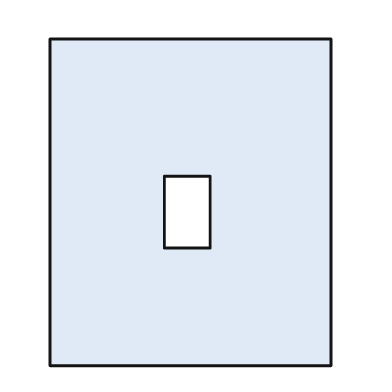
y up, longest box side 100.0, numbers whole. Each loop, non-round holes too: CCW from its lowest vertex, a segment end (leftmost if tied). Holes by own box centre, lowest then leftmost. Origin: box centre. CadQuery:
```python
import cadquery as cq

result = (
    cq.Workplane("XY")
    .moveTo(-43.0, -50.0)
    .lineTo(43.0, -50.0)
    .lineTo(43.0, 50.0)
    .lineTo(-43.0, 50.0)
    .close()
    .moveTo(-8.0, -14.0)
    .lineTo(6.0, -14.0)
    .lineTo(6.0, 8.0)
    .lineTo(-8.0, 8.0)
    .close()
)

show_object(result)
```